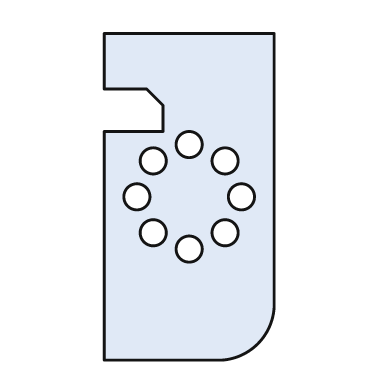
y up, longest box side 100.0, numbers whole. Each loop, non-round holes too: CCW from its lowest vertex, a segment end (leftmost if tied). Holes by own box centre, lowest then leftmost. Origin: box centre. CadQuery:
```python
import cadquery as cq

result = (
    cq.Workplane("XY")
    .moveTo(-26.0, -50.0)
    .lineTo(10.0, -50.0)
    .threePointArc((21.0, -45.0), (26.0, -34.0))
    .lineTo(26.0, 50.0)
    .lineTo(-26.0, 50.0)
    .lineTo(-26.0, 33.0)
    .lineTo(-13.0, 33.0)
    .lineTo(-8.0, 28.0)
    .lineTo(-8.0, 20.0)
    .lineTo(-26.0, 20.0)
    .close()
    .moveTo(0.0, -16.0)
    .circle(4.0)
    .moveTo(-11.0, -11.0)
    .circle(4.0)
    .moveTo(11.0, -11.0)
    .circle(4.0)
    .moveTo(-16.0, 0.0)
    .circle(4.0)
    .moveTo(16.0, 0.0)
    .circle(4.0)
    .moveTo(-11.0, 11.0)
    .circle(4.0)
    .moveTo(11.0, 11.0)
    .circle(4.0)
    .moveTo(0.0, 16.0)
    .circle(4.0)
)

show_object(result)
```